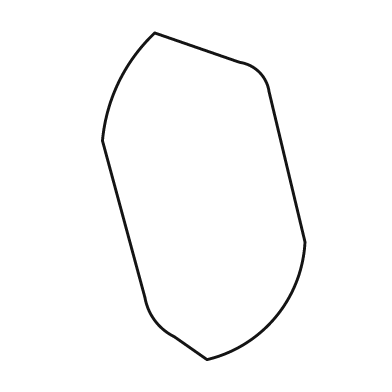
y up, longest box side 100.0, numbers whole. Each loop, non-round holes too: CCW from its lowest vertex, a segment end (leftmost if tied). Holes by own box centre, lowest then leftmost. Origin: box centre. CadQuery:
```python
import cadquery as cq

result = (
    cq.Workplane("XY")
    .moveTo(1.0, -50.0)
    .threePointArc((22.0, -37.0), (31.0, -14.0))
    .lineTo(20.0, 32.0)
    .threePointArc((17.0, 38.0), (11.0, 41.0))
    .lineTo(-15.0, 50.0)
    .threePointArc((-26.0, 35.0), (-31.0, 17.0))
    .lineTo(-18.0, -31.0)
    .threePointArc((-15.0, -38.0), (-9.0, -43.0))
    .close()
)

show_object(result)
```